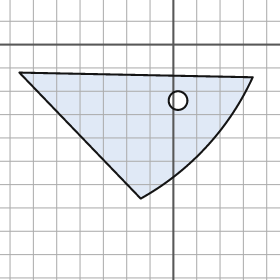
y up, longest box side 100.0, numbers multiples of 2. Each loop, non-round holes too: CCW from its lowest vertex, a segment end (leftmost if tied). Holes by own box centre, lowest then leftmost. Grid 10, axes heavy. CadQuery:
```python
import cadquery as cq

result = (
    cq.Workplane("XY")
    .moveTo(-14.0, -66.0)
    .threePointArc((14.0, -44.0), (34.0, -14.0))
    .lineTo(-66.0, -12.0)
    .close()
    .moveTo(2.0, -24.0)
    .circle(4.0)
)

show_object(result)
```